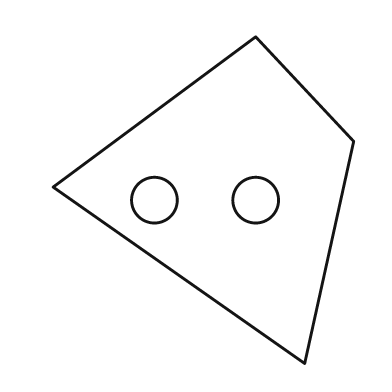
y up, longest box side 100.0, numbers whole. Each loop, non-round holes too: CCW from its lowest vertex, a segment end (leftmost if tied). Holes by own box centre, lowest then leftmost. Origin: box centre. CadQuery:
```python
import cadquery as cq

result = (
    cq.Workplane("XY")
    .moveTo(31.0, -50.0)
    .lineTo(46.0, 18.0)
    .lineTo(16.0, 50.0)
    .lineTo(-46.0, 4.0)
    .close()
    .moveTo(-15.0, 0.0)
    .circle(7.0)
    .moveTo(16.0, 0.0)
    .circle(7.0)
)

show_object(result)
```